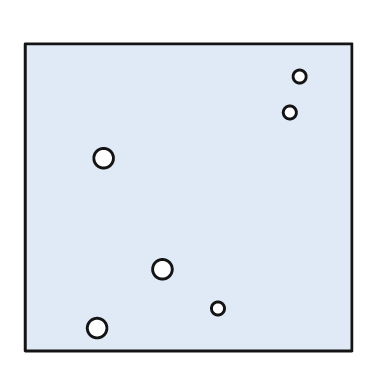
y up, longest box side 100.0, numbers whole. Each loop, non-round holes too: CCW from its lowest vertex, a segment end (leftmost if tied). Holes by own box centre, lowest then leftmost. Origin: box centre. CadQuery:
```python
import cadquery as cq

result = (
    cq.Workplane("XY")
    .moveTo(-50.0, -47.0)
    .lineTo(50.0, -47.0)
    .lineTo(50.0, 47.0)
    .lineTo(-50.0, 47.0)
    .close()
    .moveTo(-28.0, -40.0)
    .circle(3.0)
    .moveTo(9.0, -34.0)
    .circle(2.0)
    .moveTo(-8.0, -22.0)
    .circle(3.0)
    .moveTo(-26.0, 12.0)
    .circle(3.0)
    .moveTo(31.0, 26.0)
    .circle(2.0)
    .moveTo(34.0, 37.0)
    .circle(2.0)
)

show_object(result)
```